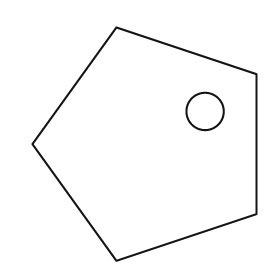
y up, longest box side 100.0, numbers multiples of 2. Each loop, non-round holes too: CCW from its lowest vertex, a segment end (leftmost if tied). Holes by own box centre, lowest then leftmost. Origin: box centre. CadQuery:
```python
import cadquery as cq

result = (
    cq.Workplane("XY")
    .moveTo(-12.0, -50.0)
    .lineTo(48.0, -30.0)
    .lineTo(48.0, 30.0)
    .lineTo(-12.0, 50.0)
    .lineTo(-48.0, 0.0)
    .close()
    .moveTo(26.0, 14.0)
    .circle(8.0)
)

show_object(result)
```